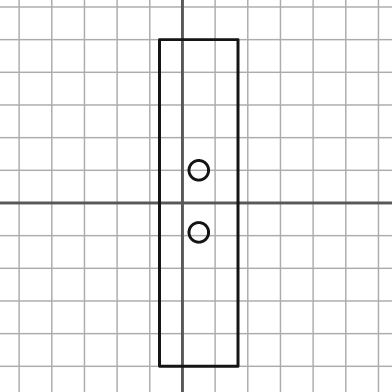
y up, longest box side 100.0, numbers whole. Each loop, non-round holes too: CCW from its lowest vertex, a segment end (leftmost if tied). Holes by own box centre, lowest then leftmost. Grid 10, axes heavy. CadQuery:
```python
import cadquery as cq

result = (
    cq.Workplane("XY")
    .moveTo(-7.0, -50.0)
    .lineTo(17.0, -50.0)
    .lineTo(17.0, 50.0)
    .lineTo(-7.0, 50.0)
    .close()
    .moveTo(5.0, -9.0)
    .circle(3.0)
    .moveTo(5.0, 10.0)
    .circle(3.0)
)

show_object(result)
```